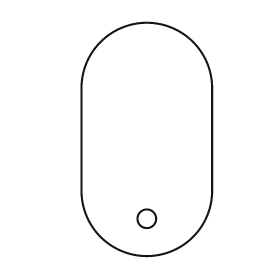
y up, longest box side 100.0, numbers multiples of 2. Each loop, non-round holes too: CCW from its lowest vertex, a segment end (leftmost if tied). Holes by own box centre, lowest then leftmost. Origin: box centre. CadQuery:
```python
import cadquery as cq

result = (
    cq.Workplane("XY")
    .moveTo(-28.0, -22.0)
    .threePointArc((0.0, -50.0), (28.0, -22.0))
    .lineTo(28.0, 22.0)
    .threePointArc((0.0, 50.0), (-28.0, 22.0))
    .close()
    .moveTo(0.0, -34.0)
    .circle(4.0)
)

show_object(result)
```